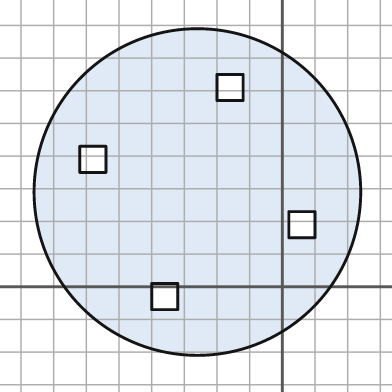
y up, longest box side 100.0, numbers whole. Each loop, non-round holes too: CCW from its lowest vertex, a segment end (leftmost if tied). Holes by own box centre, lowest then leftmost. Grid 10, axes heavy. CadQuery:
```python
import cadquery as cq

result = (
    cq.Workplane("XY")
    .moveTo(-26.0, 29.0)
    .circle(50.0)
    .moveTo(-40.0, -7.0)
    .lineTo(-32.0, -7.0)
    .lineTo(-32.0, 1.0)
    .lineTo(-40.0, 1.0)
    .close()
    .moveTo(2.0, 15.0)
    .lineTo(10.0, 15.0)
    .lineTo(10.0, 23.0)
    .lineTo(2.0, 23.0)
    .close()
    .moveTo(-62.0, 35.0)
    .lineTo(-54.0, 35.0)
    .lineTo(-54.0, 43.0)
    .lineTo(-62.0, 43.0)
    .close()
    .moveTo(-20.0, 57.0)
    .lineTo(-12.0, 57.0)
    .lineTo(-12.0, 65.0)
    .lineTo(-20.0, 65.0)
    .close()
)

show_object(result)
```